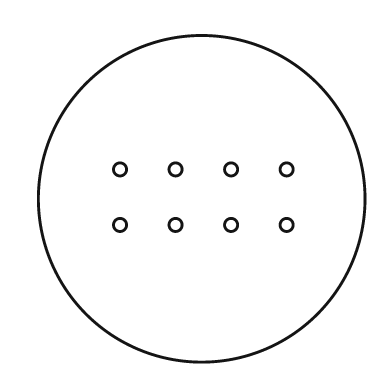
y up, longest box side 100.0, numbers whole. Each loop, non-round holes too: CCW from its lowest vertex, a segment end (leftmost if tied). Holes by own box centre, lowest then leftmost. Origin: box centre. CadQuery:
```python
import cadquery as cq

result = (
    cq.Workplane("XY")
    .moveTo(0.0, 0.0)
    .circle(50.0)
    .moveTo(-25.0, -8.0)
    .circle(2.0)
    .moveTo(-8.0, -8.0)
    .circle(2.0)
    .moveTo(9.0, -8.0)
    .circle(2.0)
    .moveTo(26.0, -8.0)
    .circle(2.0)
    .moveTo(-25.0, 9.0)
    .circle(2.0)
    .moveTo(-8.0, 9.0)
    .circle(2.0)
    .moveTo(9.0, 9.0)
    .circle(2.0)
    .moveTo(26.0, 9.0)
    .circle(2.0)
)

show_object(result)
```